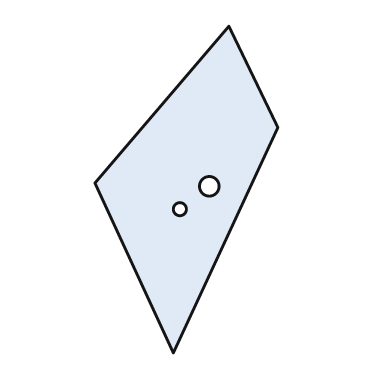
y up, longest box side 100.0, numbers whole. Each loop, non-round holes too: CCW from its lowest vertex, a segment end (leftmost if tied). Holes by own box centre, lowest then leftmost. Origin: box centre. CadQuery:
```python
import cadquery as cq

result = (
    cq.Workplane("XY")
    .moveTo(-4.0, -50.0)
    .lineTo(28.0, 19.0)
    .lineTo(13.0, 50.0)
    .lineTo(-28.0, 2.0)
    .close()
    .moveTo(-2.0, -6.0)
    .circle(2.0)
    .moveTo(7.0, 1.0)
    .circle(3.0)
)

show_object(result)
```